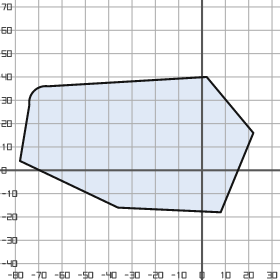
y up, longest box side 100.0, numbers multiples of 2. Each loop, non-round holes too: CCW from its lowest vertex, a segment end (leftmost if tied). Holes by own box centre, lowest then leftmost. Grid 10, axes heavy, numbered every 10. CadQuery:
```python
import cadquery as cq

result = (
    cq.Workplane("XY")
    .moveTo(8.0, -18.0)
    .lineTo(22.0, 16.0)
    .lineTo(2.0, 40.0)
    .lineTo(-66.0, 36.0)
    .threePointArc((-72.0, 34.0), (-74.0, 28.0))
    .lineTo(-78.0, 4.0)
    .lineTo(-36.0, -16.0)
    .close()
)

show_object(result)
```